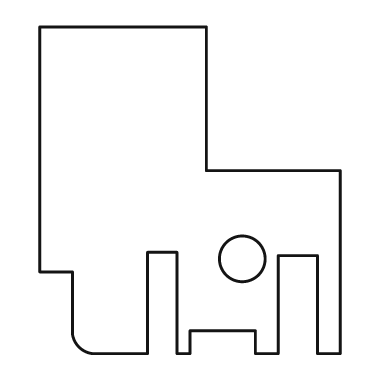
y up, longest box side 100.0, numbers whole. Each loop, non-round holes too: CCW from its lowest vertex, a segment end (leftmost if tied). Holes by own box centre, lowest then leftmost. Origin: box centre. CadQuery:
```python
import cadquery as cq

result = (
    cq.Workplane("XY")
    .moveTo(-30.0, -50.0)
    .lineTo(-13.0, -50.0)
    .lineTo(-13.0, -19.0)
    .lineTo(-4.0, -19.0)
    .lineTo(-4.0, -50.0)
    .lineTo(0.0, -50.0)
    .lineTo(0.0, -43.0)
    .lineTo(20.0, -43.0)
    .lineTo(20.0, -50.0)
    .lineTo(27.0, -50.0)
    .lineTo(27.0, -20.0)
    .lineTo(39.0, -20.0)
    .lineTo(39.0, -50.0)
    .lineTo(46.0, -50.0)
    .lineTo(46.0, 6.0)
    .lineTo(5.0, 6.0)
    .lineTo(5.0, 50.0)
    .lineTo(-46.0, 50.0)
    .lineTo(-46.0, -25.0)
    .lineTo(-36.0, -25.0)
    .lineTo(-36.0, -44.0)
    .threePointArc((-34.0, -48.0), (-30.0, -50.0))
    .close()
    .moveTo(16.0, -21.0)
    .circle(7.0)
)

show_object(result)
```